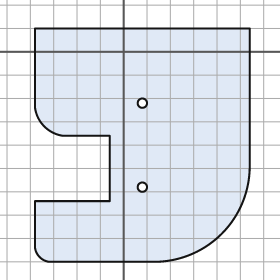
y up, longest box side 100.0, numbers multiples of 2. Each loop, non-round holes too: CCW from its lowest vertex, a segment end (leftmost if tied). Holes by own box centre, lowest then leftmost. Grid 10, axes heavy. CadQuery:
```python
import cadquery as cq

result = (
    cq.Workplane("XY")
    .moveTo(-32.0, -90.0)
    .lineTo(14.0, -90.0)
    .threePointArc((42.0, -78.0), (54.0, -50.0))
    .lineTo(54.0, 10.0)
    .lineTo(-38.0, 10.0)
    .lineTo(-38.0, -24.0)
    .threePointArc((-34.0, -32.0), (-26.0, -36.0))
    .lineTo(-6.0, -36.0)
    .lineTo(-6.0, -64.0)
    .lineTo(-38.0, -64.0)
    .lineTo(-38.0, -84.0)
    .threePointArc((-36.0, -88.0), (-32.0, -90.0))
    .close()
    .moveTo(8.0, -58.0)
    .circle(2.0)
    .moveTo(8.0, -22.0)
    .circle(2.0)
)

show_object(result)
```